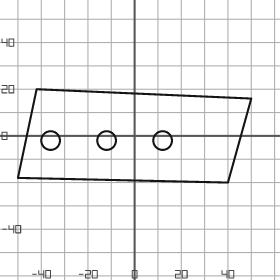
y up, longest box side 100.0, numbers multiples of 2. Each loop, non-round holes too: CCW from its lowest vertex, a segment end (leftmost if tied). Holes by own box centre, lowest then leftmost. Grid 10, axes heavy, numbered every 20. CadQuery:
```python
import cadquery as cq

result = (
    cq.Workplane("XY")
    .moveTo(40.0, -20.0)
    .lineTo(50.0, 16.0)
    .lineTo(-42.0, 20.0)
    .lineTo(-50.0, -18.0)
    .close()
    .moveTo(-36.0, -2.0)
    .circle(4.0)
    .moveTo(-12.0, -2.0)
    .circle(4.0)
    .moveTo(12.0, -2.0)
    .circle(4.0)
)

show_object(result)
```